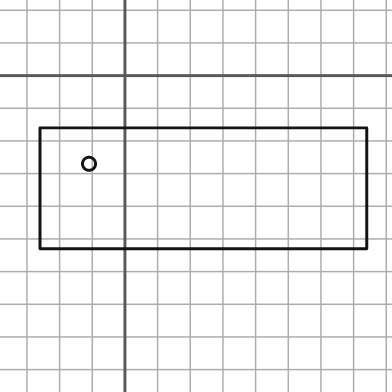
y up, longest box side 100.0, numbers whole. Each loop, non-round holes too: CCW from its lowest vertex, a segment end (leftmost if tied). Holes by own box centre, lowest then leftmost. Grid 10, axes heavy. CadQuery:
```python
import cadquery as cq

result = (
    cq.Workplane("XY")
    .moveTo(-26.0, -53.0)
    .lineTo(74.0, -53.0)
    .lineTo(74.0, -16.0)
    .lineTo(-26.0, -16.0)
    .close()
    .moveTo(-11.0, -27.0)
    .circle(2.0)
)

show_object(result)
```